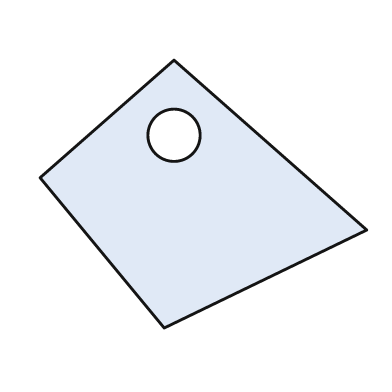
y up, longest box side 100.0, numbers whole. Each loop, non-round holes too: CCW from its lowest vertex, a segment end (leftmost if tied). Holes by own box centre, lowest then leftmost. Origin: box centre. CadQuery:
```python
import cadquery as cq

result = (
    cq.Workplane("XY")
    .moveTo(-12.0, -41.0)
    .lineTo(50.0, -11.0)
    .lineTo(-9.0, 41.0)
    .lineTo(-50.0, 5.0)
    .close()
    .moveTo(-9.0, 18.0)
    .circle(8.0)
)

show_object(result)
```